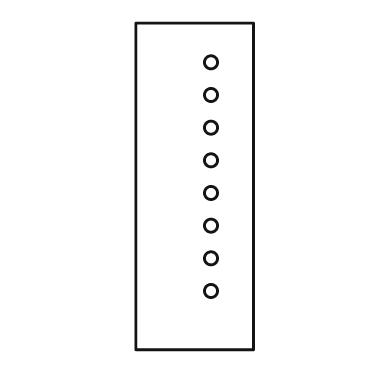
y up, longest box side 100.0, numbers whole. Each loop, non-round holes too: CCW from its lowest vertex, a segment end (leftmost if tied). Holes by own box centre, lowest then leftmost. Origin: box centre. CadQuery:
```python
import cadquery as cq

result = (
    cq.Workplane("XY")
    .moveTo(-18.0, -50.0)
    .lineTo(18.0, -50.0)
    .lineTo(18.0, 50.0)
    .lineTo(-18.0, 50.0)
    .close()
    .moveTo(5.0, -32.0)
    .circle(2.0)
    .moveTo(5.0, -22.0)
    .circle(2.0)
    .moveTo(5.0, -12.0)
    .circle(2.0)
    .moveTo(5.0, -2.0)
    .circle(2.0)
    .moveTo(5.0, 8.0)
    .circle(2.0)
    .moveTo(5.0, 18.0)
    .circle(2.0)
    .moveTo(5.0, 28.0)
    .circle(2.0)
    .moveTo(5.0, 38.0)
    .circle(2.0)
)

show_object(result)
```